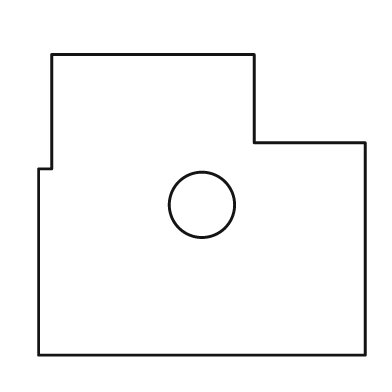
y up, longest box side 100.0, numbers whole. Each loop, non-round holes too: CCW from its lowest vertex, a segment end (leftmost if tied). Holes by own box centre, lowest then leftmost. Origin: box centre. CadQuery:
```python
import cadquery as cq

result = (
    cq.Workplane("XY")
    .moveTo(-50.0, -46.0)
    .lineTo(50.0, -46.0)
    .lineTo(50.0, 19.0)
    .lineTo(16.0, 19.0)
    .lineTo(16.0, 46.0)
    .lineTo(-46.0, 46.0)
    .lineTo(-46.0, 11.0)
    .lineTo(-50.0, 11.0)
    .close()
    .moveTo(0.0, 0.0)
    .circle(10.0)
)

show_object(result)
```